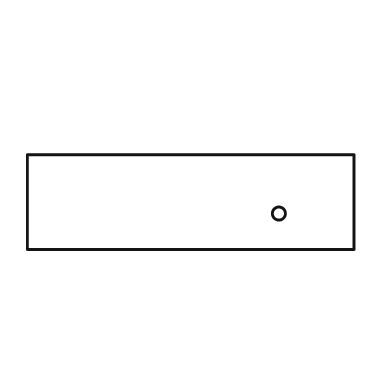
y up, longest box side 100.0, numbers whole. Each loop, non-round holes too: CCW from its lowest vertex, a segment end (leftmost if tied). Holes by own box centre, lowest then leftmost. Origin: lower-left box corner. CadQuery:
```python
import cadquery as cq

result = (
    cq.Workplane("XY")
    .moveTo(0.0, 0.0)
    .lineTo(100.0, 0.0)
    .lineTo(100.0, 29.0)
    .lineTo(0.0, 29.0)
    .close()
    .moveTo(77.0, 11.0)
    .circle(2.0)
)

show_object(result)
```